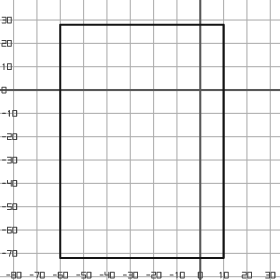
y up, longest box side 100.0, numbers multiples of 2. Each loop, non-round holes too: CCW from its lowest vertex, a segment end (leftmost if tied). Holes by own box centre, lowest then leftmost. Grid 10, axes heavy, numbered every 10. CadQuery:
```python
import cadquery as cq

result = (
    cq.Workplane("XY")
    .moveTo(-60.0, -72.0)
    .lineTo(10.0, -72.0)
    .lineTo(10.0, 28.0)
    .lineTo(-60.0, 28.0)
    .close()
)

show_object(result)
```